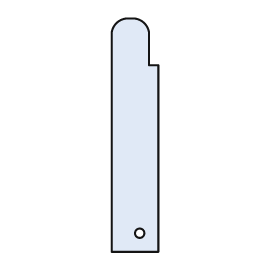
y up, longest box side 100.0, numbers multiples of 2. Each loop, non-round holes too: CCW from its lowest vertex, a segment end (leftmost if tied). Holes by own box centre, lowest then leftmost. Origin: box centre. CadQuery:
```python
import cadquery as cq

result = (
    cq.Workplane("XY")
    .moveTo(-10.0, -50.0)
    .lineTo(10.0, -50.0)
    .lineTo(10.0, 30.0)
    .lineTo(6.0, 30.0)
    .lineTo(6.0, 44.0)
    .threePointArc((4.0, 48.0), (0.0, 50.0))
    .lineTo(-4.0, 50.0)
    .threePointArc((-8.0, 48.0), (-10.0, 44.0))
    .close()
    .moveTo(2.0, -42.0)
    .circle(2.0)
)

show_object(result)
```